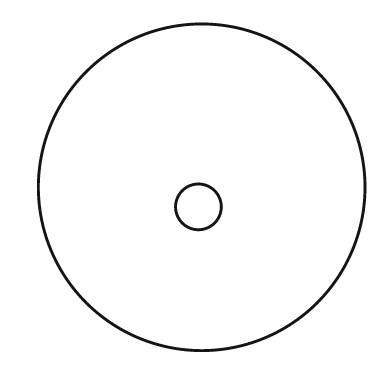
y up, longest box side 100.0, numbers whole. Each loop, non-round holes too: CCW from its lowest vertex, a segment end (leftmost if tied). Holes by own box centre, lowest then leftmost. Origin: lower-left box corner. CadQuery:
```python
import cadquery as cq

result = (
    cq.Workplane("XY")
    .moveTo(50.0, 50.0)
    .circle(50.0)
    .moveTo(49.0, 44.0)
    .circle(7.0)
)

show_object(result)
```